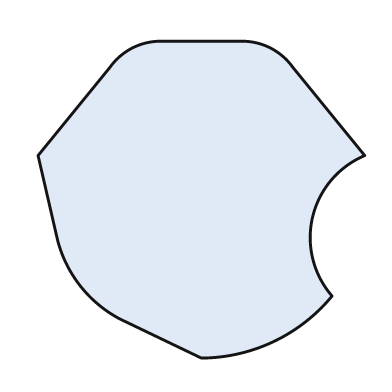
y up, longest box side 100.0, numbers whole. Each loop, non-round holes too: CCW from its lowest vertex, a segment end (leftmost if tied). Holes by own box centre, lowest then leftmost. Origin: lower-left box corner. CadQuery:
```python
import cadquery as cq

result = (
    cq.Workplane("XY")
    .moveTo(50.0, 0.0)
    .threePointArc((72.0, 5.0), (90.0, 19.0))
    .threePointArc((84.0, 43.0), (100.0, 62.0))
    .lineTo(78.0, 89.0)
    .threePointArc((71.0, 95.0), (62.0, 97.0))
    .lineTo(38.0, 97.0)
    .threePointArc((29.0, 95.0), (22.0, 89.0))
    .lineTo(0.0, 62.0)
    .lineTo(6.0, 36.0)
    .threePointArc((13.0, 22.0), (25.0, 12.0))
    .close()
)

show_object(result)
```